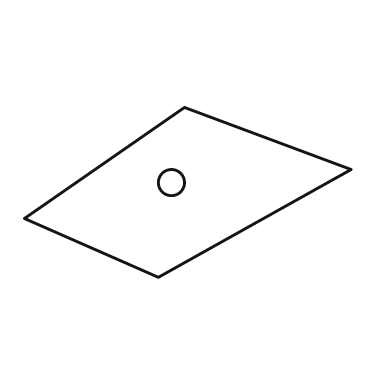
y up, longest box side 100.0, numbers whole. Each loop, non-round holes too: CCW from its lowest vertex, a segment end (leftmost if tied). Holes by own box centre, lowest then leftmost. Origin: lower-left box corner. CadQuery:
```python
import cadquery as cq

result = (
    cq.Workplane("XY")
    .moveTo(41.0, 0.0)
    .lineTo(100.0, 33.0)
    .lineTo(49.0, 52.0)
    .lineTo(0.0, 18.0)
    .close()
    .moveTo(45.0, 29.0)
    .circle(4.0)
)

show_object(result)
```